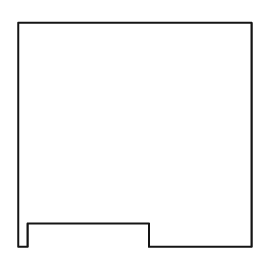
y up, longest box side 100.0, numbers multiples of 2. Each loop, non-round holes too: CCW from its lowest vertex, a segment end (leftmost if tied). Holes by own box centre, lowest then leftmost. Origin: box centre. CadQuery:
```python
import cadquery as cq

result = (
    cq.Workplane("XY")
    .moveTo(-50.0, -48.0)
    .lineTo(-46.0, -48.0)
    .lineTo(-46.0, -38.0)
    .lineTo(6.0, -38.0)
    .lineTo(6.0, -48.0)
    .lineTo(50.0, -48.0)
    .lineTo(50.0, 48.0)
    .lineTo(-50.0, 48.0)
    .close()
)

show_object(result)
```